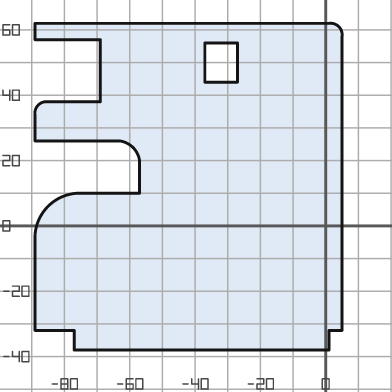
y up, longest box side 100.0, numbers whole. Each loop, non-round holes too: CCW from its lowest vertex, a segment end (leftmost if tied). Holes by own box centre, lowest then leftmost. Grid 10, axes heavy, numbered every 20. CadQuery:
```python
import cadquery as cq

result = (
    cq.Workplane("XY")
    .moveTo(-77.0, -38.0)
    .lineTo(1.0, -38.0)
    .lineTo(1.0, -32.0)
    .lineTo(5.0, -32.0)
    .lineTo(5.0, 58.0)
    .threePointArc((4.0, 61.0), (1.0, 62.0))
    .lineTo(-89.0, 62.0)
    .lineTo(-89.0, 57.0)
    .lineTo(-69.0, 57.0)
    .lineTo(-69.0, 38.0)
    .lineTo(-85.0, 38.0)
    .threePointArc((-88.0, 37.0), (-89.0, 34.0))
    .lineTo(-89.0, 26.0)
    .lineTo(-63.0, 26.0)
    .threePointArc((-59.0, 24.0), (-57.0, 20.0))
    .lineTo(-57.0, 10.0)
    .lineTo(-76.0, 10.0)
    .threePointArc((-85.0, 6.0), (-89.0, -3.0))
    .lineTo(-89.0, -32.0)
    .lineTo(-77.0, -32.0)
    .close()
    .moveTo(-37.0, 44.0)
    .lineTo(-27.0, 44.0)
    .lineTo(-27.0, 56.0)
    .lineTo(-37.0, 56.0)
    .close()
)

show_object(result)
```